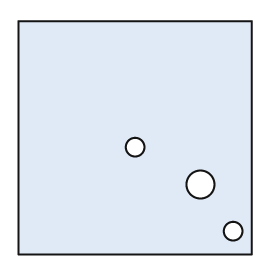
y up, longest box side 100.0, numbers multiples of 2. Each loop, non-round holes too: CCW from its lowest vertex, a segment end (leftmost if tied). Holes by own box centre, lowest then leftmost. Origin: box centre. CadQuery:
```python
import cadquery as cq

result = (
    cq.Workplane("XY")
    .moveTo(-50.0, -50.0)
    .lineTo(50.0, -50.0)
    .lineTo(50.0, 50.0)
    .lineTo(-50.0, 50.0)
    .close()
    .moveTo(42.0, -40.0)
    .circle(4.0)
    .moveTo(28.0, -20.0)
    .circle(6.0)
    .moveTo(0.0, -4.0)
    .circle(4.0)
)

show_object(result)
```